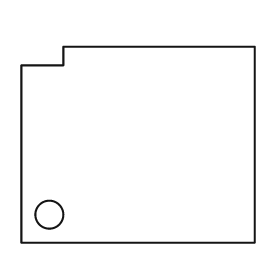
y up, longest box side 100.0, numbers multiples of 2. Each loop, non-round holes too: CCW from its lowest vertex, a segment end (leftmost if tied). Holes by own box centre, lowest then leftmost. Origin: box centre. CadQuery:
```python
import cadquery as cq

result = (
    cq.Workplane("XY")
    .moveTo(-50.0, -42.0)
    .lineTo(50.0, -42.0)
    .lineTo(50.0, 42.0)
    .lineTo(-32.0, 42.0)
    .lineTo(-32.0, 34.0)
    .lineTo(-50.0, 34.0)
    .close()
    .moveTo(-38.0, -30.0)
    .circle(6.0)
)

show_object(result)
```